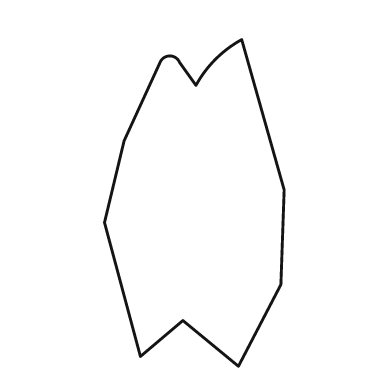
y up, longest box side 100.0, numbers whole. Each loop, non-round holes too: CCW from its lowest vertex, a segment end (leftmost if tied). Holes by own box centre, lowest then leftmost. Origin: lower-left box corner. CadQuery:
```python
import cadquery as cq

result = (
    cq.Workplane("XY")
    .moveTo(41.0, 0.0)
    .lineTo(54.0, 25.0)
    .lineTo(55.0, 54.0)
    .lineTo(42.0, 100.0)
    .threePointArc((34.0, 94.0), (28.0, 86.0))
    .lineTo(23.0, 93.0)
    .threePointArc((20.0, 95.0), (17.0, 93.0))
    .lineTo(6.0, 69.0)
    .lineTo(0.0, 44.0)
    .lineTo(11.0, 3.0)
    .lineTo(24.0, 14.0)
    .close()
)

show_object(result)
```